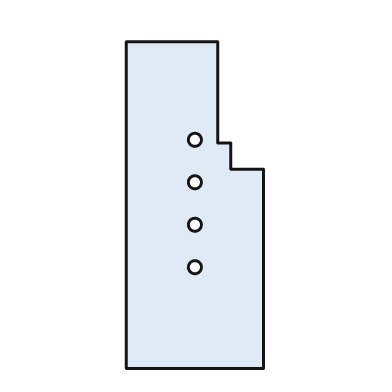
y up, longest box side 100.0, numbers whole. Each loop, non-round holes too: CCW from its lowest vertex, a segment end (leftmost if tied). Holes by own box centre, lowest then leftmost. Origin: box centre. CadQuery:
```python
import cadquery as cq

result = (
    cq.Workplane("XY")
    .moveTo(-21.0, -50.0)
    .lineTo(21.0, -50.0)
    .lineTo(21.0, 11.0)
    .lineTo(11.0, 11.0)
    .lineTo(11.0, 19.0)
    .lineTo(7.0, 19.0)
    .lineTo(7.0, 50.0)
    .lineTo(-21.0, 50.0)
    .close()
    .moveTo(0.0, -19.0)
    .circle(2.0)
    .moveTo(0.0, -6.0)
    .circle(2.0)
    .moveTo(0.0, 7.0)
    .circle(2.0)
    .moveTo(0.0, 20.0)
    .circle(2.0)
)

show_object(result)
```